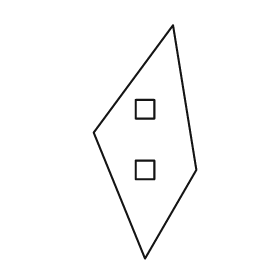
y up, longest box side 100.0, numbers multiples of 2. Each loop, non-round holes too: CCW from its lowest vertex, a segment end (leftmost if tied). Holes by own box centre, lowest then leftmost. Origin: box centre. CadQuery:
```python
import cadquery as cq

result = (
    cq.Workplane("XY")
    .moveTo(0.0, -50.0)
    .lineTo(22.0, -12.0)
    .lineTo(12.0, 50.0)
    .lineTo(-22.0, 4.0)
    .close()
    .moveTo(-4.0, -16.0)
    .lineTo(4.0, -16.0)
    .lineTo(4.0, -8.0)
    .lineTo(-4.0, -8.0)
    .close()
    .moveTo(-4.0, 10.0)
    .lineTo(4.0, 10.0)
    .lineTo(4.0, 18.0)
    .lineTo(-4.0, 18.0)
    .close()
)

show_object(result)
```